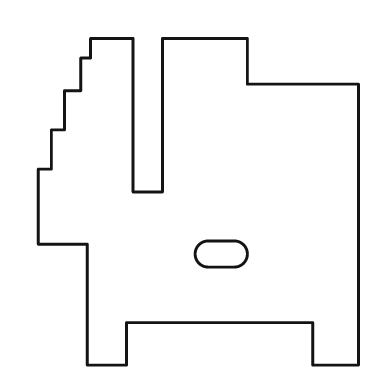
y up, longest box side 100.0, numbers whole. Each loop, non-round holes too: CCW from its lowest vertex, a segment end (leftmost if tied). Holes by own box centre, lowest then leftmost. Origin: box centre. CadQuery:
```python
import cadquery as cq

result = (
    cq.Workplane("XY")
    .moveTo(-34.0, -50.0)
    .lineTo(-22.0, -50.0)
    .lineTo(-22.0, -37.0)
    .lineTo(35.0, -37.0)
    .lineTo(35.0, -50.0)
    .lineTo(49.0, -50.0)
    .lineTo(49.0, 36.0)
    .lineTo(15.0, 36.0)
    .lineTo(15.0, 50.0)
    .lineTo(-11.0, 50.0)
    .lineTo(-11.0, 3.0)
    .lineTo(-20.0, 3.0)
    .lineTo(-20.0, 50.0)
    .lineTo(-33.0, 50.0)
    .lineTo(-33.0, 44.0)
    .lineTo(-36.0, 44.0)
    .lineTo(-36.0, 34.0)
    .lineTo(-41.0, 34.0)
    .lineTo(-41.0, 22.0)
    .lineTo(-45.0, 22.0)
    .lineTo(-45.0, 10.0)
    .lineTo(-49.0, 10.0)
    .lineTo(-49.0, -13.0)
    .lineTo(-34.0, -13.0)
    .close()
    .moveTo(3.0, -20.0)
    .lineTo(11.0, -20.0)
    .threePointArc((15.0, -16.0), (11.0, -12.0))
    .lineTo(3.0, -12.0)
    .threePointArc((-1.0, -16.0), (3.0, -20.0))
    .close()
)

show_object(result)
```